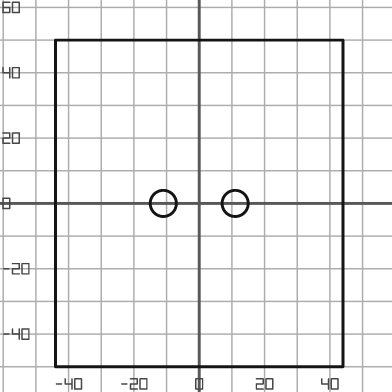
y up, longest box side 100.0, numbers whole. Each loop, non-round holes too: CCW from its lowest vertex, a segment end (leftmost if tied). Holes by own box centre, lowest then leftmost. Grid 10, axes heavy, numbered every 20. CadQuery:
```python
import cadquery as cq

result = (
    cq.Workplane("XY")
    .moveTo(-44.0, -50.0)
    .lineTo(44.0, -50.0)
    .lineTo(44.0, 50.0)
    .lineTo(-44.0, 50.0)
    .close()
    .moveTo(-11.0, 0.0)
    .circle(4.0)
    .moveTo(11.0, 0.0)
    .circle(4.0)
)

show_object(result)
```